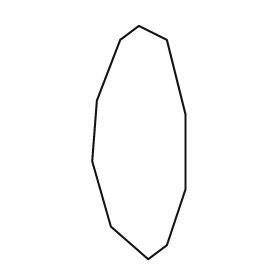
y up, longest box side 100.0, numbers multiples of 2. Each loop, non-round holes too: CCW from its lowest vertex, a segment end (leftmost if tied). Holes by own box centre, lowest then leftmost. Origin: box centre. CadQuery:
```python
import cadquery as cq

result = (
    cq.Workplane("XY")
    .moveTo(4.0, -50.0)
    .lineTo(12.0, -44.0)
    .lineTo(20.0, -20.0)
    .lineTo(20.0, 12.0)
    .lineTo(12.0, 44.0)
    .lineTo(0.0, 50.0)
    .lineTo(-8.0, 44.0)
    .lineTo(-18.0, 18.0)
    .lineTo(-20.0, -8.0)
    .lineTo(-12.0, -36.0)
    .close()
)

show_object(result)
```